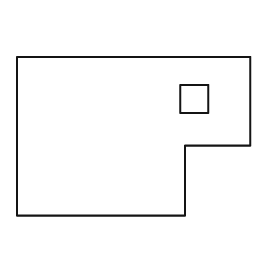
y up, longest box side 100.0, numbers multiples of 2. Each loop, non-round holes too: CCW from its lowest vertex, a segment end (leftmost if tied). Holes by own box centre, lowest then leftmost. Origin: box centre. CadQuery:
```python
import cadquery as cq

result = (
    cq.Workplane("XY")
    .moveTo(-50.0, -34.0)
    .lineTo(22.0, -34.0)
    .lineTo(22.0, -4.0)
    .lineTo(50.0, -4.0)
    .lineTo(50.0, 34.0)
    .lineTo(-50.0, 34.0)
    .close()
    .moveTo(20.0, 10.0)
    .lineTo(32.0, 10.0)
    .lineTo(32.0, 22.0)
    .lineTo(20.0, 22.0)
    .close()
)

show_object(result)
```